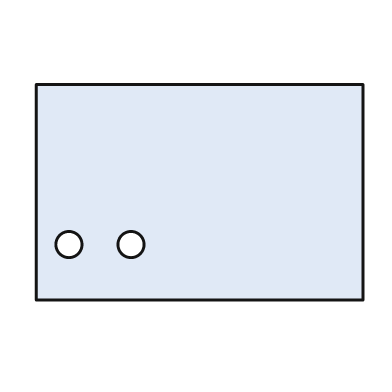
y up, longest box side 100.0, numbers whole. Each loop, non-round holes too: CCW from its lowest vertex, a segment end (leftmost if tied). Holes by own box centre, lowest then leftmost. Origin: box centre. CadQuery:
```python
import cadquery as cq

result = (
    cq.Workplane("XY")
    .moveTo(-50.0, -33.0)
    .lineTo(50.0, -33.0)
    .lineTo(50.0, 33.0)
    .lineTo(-50.0, 33.0)
    .close()
    .moveTo(-40.0, -16.0)
    .circle(4.0)
    .moveTo(-21.0, -16.0)
    .circle(4.0)
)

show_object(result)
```